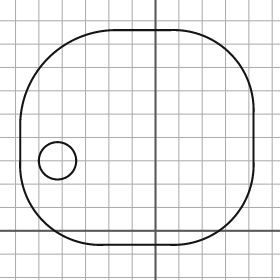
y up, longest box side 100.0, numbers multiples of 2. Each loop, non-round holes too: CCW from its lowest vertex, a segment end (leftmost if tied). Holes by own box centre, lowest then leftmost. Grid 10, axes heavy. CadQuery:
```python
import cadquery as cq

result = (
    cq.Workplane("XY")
    .moveTo(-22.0, -6.0)
    .lineTo(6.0, -6.0)
    .threePointArc((32.0, 4.0), (42.0, 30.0))
    .lineTo(42.0, 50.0)
    .threePointArc((32.0, 76.0), (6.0, 86.0))
    .lineTo(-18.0, 86.0)
    .threePointArc((-46.0, 74.0), (-58.0, 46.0))
    .lineTo(-58.0, 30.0)
    .threePointArc((-48.0, 4.0), (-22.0, -6.0))
    .close()
    .moveTo(-42.0, 30.0)
    .circle(8.0)
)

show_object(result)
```